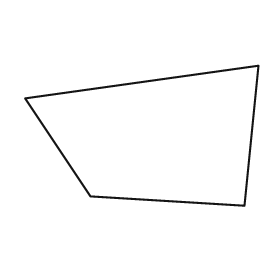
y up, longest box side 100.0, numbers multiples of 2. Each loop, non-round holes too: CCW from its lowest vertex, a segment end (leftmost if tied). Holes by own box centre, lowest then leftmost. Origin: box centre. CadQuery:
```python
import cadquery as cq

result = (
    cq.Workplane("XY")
    .moveTo(44.0, -30.0)
    .lineTo(50.0, 30.0)
    .lineTo(-50.0, 16.0)
    .lineTo(-22.0, -26.0)
    .close()
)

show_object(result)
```